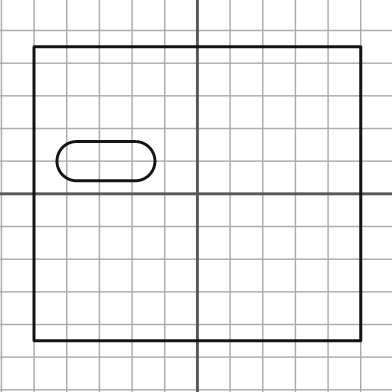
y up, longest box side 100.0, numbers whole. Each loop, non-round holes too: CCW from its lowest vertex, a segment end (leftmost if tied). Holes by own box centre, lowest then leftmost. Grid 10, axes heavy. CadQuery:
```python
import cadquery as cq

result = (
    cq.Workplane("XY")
    .moveTo(-50.0, -45.0)
    .lineTo(50.0, -45.0)
    .lineTo(50.0, 45.0)
    .lineTo(-50.0, 45.0)
    .close()
    .moveTo(-37.0, 4.0)
    .lineTo(-19.0, 4.0)
    .threePointArc((-13.0, 10.0), (-19.0, 16.0))
    .lineTo(-37.0, 16.0)
    .threePointArc((-43.0, 10.0), (-37.0, 4.0))
    .close()
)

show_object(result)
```